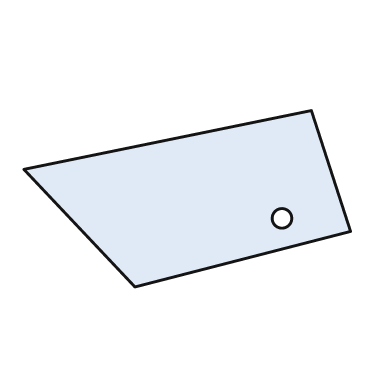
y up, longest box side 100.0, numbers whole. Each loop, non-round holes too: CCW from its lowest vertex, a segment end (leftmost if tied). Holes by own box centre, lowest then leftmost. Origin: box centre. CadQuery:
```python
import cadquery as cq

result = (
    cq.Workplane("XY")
    .moveTo(-16.0, -27.0)
    .lineTo(50.0, -10.0)
    .lineTo(38.0, 27.0)
    .lineTo(-50.0, 9.0)
    .close()
    .moveTo(29.0, -6.0)
    .circle(3.0)
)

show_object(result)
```